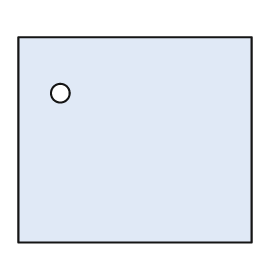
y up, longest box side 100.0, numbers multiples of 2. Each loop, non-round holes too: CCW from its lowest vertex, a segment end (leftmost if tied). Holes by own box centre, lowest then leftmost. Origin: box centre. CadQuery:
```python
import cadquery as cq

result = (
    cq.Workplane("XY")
    .moveTo(-50.0, -44.0)
    .lineTo(50.0, -44.0)
    .lineTo(50.0, 44.0)
    .lineTo(-50.0, 44.0)
    .close()
    .moveTo(-32.0, 20.0)
    .circle(4.0)
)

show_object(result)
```